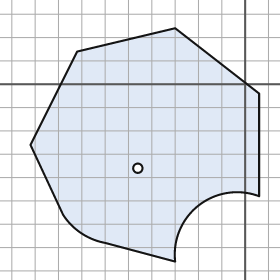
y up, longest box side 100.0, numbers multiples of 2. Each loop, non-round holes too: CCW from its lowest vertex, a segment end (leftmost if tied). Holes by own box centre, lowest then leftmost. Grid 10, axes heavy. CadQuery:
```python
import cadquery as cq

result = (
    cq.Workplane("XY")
    .moveTo(-30.0, -76.0)
    .threePointArc((-20.0, -52.0), (6.0, -48.0))
    .lineTo(6.0, -4.0)
    .lineTo(-30.0, 24.0)
    .lineTo(-72.0, 14.0)
    .lineTo(-92.0, -26.0)
    .lineTo(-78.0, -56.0)
    .threePointArc((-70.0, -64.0), (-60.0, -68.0))
    .close()
    .moveTo(-46.0, -36.0)
    .circle(2.0)
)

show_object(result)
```